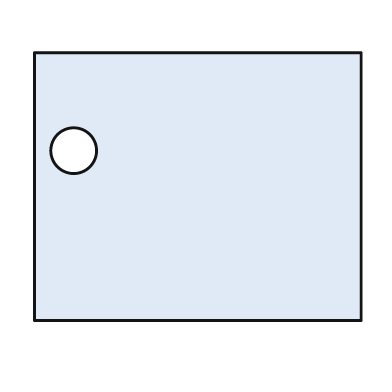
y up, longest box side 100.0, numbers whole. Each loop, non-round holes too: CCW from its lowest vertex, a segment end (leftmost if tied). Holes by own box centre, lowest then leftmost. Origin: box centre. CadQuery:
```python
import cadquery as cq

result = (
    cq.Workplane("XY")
    .moveTo(-50.0, -41.0)
    .lineTo(50.0, -41.0)
    .lineTo(50.0, 41.0)
    .lineTo(-50.0, 41.0)
    .close()
    .moveTo(-38.0, 11.0)
    .circle(7.0)
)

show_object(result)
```